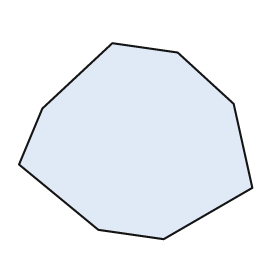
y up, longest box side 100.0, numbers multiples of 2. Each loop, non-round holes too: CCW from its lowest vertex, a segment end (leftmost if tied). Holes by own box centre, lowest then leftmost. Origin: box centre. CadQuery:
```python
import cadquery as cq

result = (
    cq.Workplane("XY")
    .moveTo(12.0, -42.0)
    .lineTo(50.0, -20.0)
    .lineTo(42.0, 16.0)
    .lineTo(18.0, 38.0)
    .lineTo(-10.0, 42.0)
    .lineTo(-40.0, 14.0)
    .lineTo(-50.0, -10.0)
    .lineTo(-16.0, -38.0)
    .close()
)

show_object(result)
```